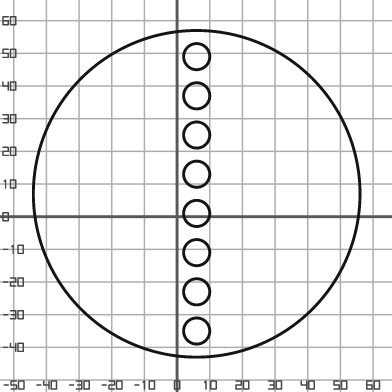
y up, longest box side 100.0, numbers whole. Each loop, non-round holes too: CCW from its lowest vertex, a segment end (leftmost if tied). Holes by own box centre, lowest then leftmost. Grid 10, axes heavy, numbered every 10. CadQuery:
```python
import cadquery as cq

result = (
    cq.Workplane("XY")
    .moveTo(6.0, 7.0)
    .circle(50.0)
    .moveTo(6.0, -35.0)
    .circle(4.0)
    .moveTo(6.0, -23.0)
    .circle(4.0)
    .moveTo(6.0, -11.0)
    .circle(4.0)
    .moveTo(6.0, 1.0)
    .circle(4.0)
    .moveTo(6.0, 13.0)
    .circle(4.0)
    .moveTo(6.0, 25.0)
    .circle(4.0)
    .moveTo(6.0, 37.0)
    .circle(4.0)
    .moveTo(6.0, 49.0)
    .circle(4.0)
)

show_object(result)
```